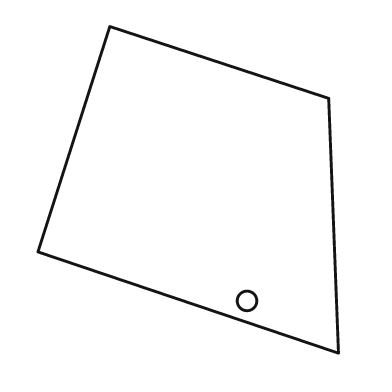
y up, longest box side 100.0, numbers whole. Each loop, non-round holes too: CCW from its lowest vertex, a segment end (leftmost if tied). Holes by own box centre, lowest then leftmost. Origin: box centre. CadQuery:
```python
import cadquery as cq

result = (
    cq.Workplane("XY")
    .moveTo(46.0, -50.0)
    .lineTo(43.0, 28.0)
    .lineTo(-24.0, 50.0)
    .lineTo(-46.0, -19.0)
    .close()
    .moveTo(18.0, -34.0)
    .circle(3.0)
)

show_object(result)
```